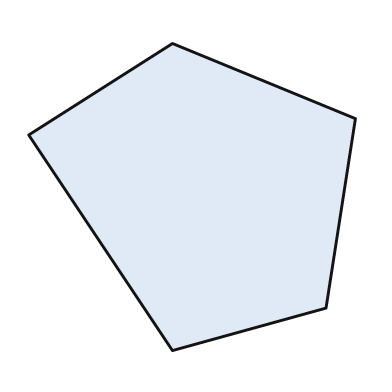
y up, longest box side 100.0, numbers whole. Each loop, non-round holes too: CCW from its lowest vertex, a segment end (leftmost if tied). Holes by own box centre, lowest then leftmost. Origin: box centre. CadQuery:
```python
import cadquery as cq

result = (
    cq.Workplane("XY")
    .moveTo(-6.0, -47.0)
    .lineTo(41.0, -34.0)
    .lineTo(50.0, 24.0)
    .lineTo(-6.0, 47.0)
    .lineTo(-50.0, 19.0)
    .close()
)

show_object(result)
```